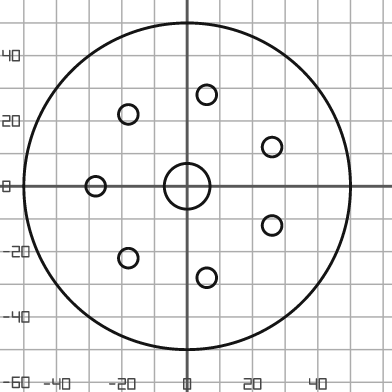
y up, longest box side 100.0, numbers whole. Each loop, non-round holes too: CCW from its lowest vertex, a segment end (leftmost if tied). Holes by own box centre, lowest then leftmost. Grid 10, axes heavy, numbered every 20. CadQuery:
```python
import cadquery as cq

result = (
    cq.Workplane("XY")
    .moveTo(0.0, 0.0)
    .circle(50.0)
    .moveTo(6.0, -28.0)
    .circle(3.0)
    .moveTo(-18.0, -22.0)
    .circle(3.0)
    .moveTo(26.0, -12.0)
    .circle(3.0)
    .moveTo(-28.0, 0.0)
    .circle(3.0)
    .moveTo(0.0, 0.0)
    .circle(7.0)
    .moveTo(26.0, 12.0)
    .circle(3.0)
    .moveTo(-18.0, 22.0)
    .circle(3.0)
    .moveTo(6.0, 28.0)
    .circle(3.0)
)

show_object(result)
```